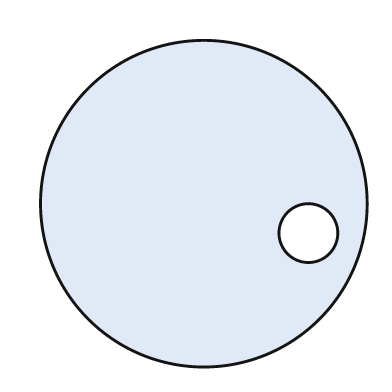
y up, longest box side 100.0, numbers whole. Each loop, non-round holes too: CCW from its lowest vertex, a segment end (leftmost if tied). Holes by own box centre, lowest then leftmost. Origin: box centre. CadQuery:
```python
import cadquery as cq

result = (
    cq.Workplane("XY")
    .moveTo(0.0, 0.0)
    .circle(50.0)
    .moveTo(32.0, -9.0)
    .circle(9.0)
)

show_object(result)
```